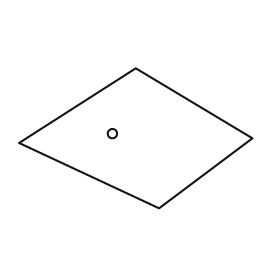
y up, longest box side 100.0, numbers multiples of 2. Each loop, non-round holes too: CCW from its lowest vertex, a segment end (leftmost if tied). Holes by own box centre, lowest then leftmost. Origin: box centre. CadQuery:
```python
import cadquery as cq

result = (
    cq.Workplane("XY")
    .moveTo(10.0, -30.0)
    .lineTo(50.0, 0.0)
    .lineTo(0.0, 30.0)
    .lineTo(-50.0, -2.0)
    .close()
    .moveTo(-10.0, 2.0)
    .circle(2.0)
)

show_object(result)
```